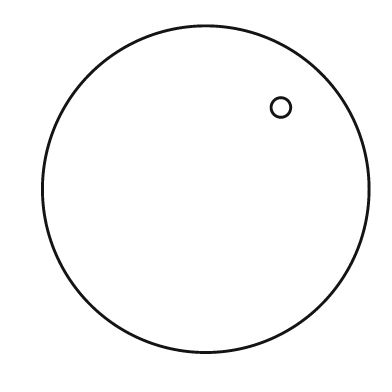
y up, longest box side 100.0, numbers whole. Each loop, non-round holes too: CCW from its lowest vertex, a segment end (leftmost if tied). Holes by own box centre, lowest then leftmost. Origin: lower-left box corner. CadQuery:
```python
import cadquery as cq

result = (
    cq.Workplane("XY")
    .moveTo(50.0, 50.0)
    .circle(50.0)
    .moveTo(73.0, 75.0)
    .circle(3.0)
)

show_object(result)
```